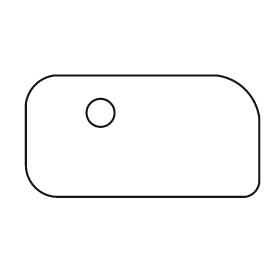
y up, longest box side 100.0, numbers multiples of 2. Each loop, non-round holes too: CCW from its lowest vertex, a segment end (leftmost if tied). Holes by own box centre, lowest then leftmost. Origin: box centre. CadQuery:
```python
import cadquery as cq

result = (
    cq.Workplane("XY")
    .moveTo(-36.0, -26.0)
    .lineTo(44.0, -26.0)
    .threePointArc((48.0, -24.0), (50.0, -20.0))
    .lineTo(50.0, 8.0)
    .threePointArc((44.0, 20.0), (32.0, 26.0))
    .lineTo(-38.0, 26.0)
    .threePointArc((-46.0, 22.0), (-50.0, 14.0))
    .lineTo(-50.0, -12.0)
    .threePointArc((-46.0, -22.0), (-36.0, -26.0))
    .close()
    .moveTo(-18.0, 10.0)
    .circle(6.0)
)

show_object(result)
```